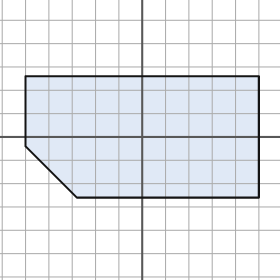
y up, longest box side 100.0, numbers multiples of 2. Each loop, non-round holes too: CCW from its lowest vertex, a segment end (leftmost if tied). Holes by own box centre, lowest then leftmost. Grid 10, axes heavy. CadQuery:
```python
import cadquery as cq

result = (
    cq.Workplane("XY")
    .moveTo(-28.0, -26.0)
    .lineTo(50.0, -26.0)
    .lineTo(50.0, 26.0)
    .lineTo(-50.0, 26.0)
    .lineTo(-50.0, -4.0)
    .close()
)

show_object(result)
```